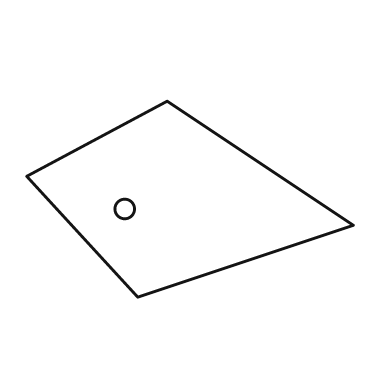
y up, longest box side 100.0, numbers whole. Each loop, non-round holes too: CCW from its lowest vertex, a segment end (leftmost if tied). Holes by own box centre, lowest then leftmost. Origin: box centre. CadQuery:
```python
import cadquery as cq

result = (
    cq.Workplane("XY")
    .moveTo(-16.0, -30.0)
    .lineTo(50.0, -8.0)
    .lineTo(-7.0, 30.0)
    .lineTo(-50.0, 7.0)
    .close()
    .moveTo(-20.0, -3.0)
    .circle(3.0)
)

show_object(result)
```